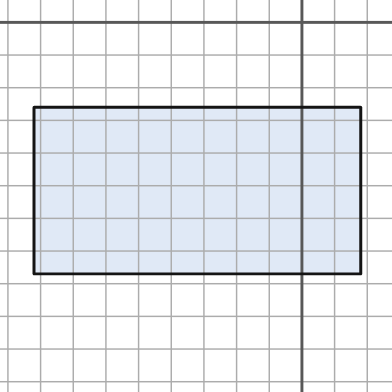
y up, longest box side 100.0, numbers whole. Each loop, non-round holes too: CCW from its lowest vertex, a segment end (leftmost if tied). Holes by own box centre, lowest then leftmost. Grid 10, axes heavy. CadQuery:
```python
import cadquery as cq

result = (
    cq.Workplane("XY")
    .moveTo(-82.0, -77.0)
    .lineTo(18.0, -77.0)
    .lineTo(18.0, -26.0)
    .lineTo(-82.0, -26.0)
    .close()
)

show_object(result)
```